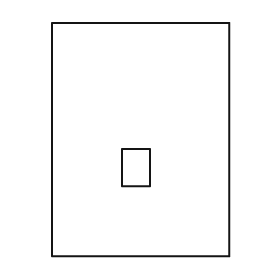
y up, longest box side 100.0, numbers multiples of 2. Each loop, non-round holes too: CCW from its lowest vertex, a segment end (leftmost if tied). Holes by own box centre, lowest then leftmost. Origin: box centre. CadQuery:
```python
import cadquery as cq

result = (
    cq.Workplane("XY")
    .moveTo(-38.0, -50.0)
    .lineTo(38.0, -50.0)
    .lineTo(38.0, 50.0)
    .lineTo(-38.0, 50.0)
    .close()
    .moveTo(-8.0, -20.0)
    .lineTo(4.0, -20.0)
    .lineTo(4.0, -4.0)
    .lineTo(-8.0, -4.0)
    .close()
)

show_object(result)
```